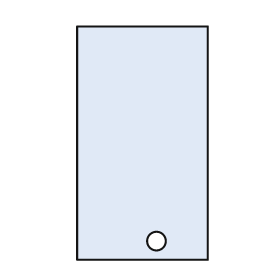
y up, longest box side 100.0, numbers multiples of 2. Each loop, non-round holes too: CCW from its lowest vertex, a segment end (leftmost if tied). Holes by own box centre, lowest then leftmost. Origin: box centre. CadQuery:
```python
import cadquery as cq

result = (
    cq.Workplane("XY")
    .moveTo(-28.0, -50.0)
    .lineTo(28.0, -50.0)
    .lineTo(28.0, 50.0)
    .lineTo(-28.0, 50.0)
    .close()
    .moveTo(6.0, -42.0)
    .circle(4.0)
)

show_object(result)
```